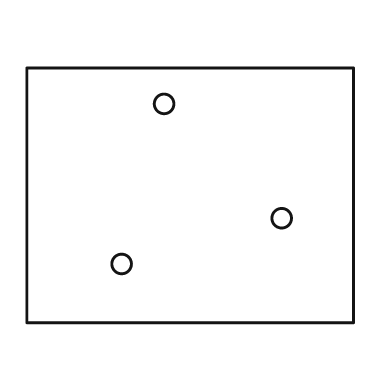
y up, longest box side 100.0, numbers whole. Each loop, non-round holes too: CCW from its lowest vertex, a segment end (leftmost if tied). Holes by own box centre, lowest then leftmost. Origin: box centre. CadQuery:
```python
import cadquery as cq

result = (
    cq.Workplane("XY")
    .moveTo(-50.0, -39.0)
    .lineTo(50.0, -39.0)
    .lineTo(50.0, 39.0)
    .lineTo(-50.0, 39.0)
    .close()
    .moveTo(-21.0, -21.0)
    .circle(3.0)
    .moveTo(28.0, -7.0)
    .circle(3.0)
    .moveTo(-8.0, 28.0)
    .circle(3.0)
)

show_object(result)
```